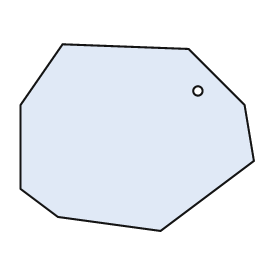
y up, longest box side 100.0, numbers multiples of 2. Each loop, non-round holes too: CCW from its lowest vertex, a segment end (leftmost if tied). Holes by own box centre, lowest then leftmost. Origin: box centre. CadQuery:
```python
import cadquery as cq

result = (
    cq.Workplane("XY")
    .moveTo(10.0, -40.0)
    .lineTo(50.0, -10.0)
    .lineTo(46.0, 14.0)
    .lineTo(22.0, 38.0)
    .lineTo(-32.0, 40.0)
    .lineTo(-50.0, 14.0)
    .lineTo(-50.0, -22.0)
    .lineTo(-34.0, -34.0)
    .close()
    .moveTo(26.0, 20.0)
    .circle(2.0)
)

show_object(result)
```